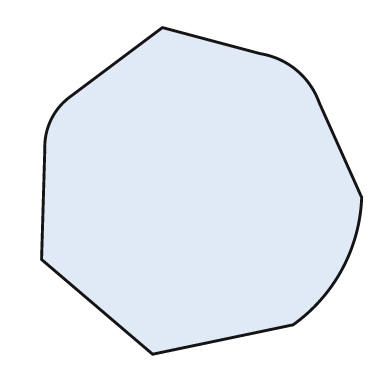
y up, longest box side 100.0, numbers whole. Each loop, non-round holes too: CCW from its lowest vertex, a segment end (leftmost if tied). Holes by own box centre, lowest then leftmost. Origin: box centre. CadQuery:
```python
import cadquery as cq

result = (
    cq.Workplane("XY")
    .moveTo(-15.0, -50.0)
    .lineTo(28.0, -41.0)
    .threePointArc((43.0, -24.0), (49.0, -2.0))
    .lineTo(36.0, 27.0)
    .threePointArc((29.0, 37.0), (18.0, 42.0))
    .lineTo(-12.0, 50.0)
    .lineTo(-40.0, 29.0)
    .threePointArc((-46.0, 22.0), (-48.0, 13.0))
    .lineTo(-49.0, -21.0)
    .close()
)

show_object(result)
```